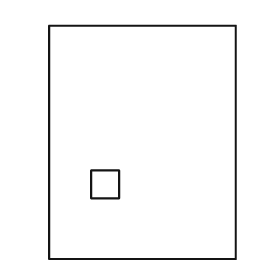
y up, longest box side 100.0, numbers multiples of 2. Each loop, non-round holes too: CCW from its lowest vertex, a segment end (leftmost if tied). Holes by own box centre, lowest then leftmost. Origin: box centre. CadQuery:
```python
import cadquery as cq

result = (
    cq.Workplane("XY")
    .moveTo(-40.0, -50.0)
    .lineTo(40.0, -50.0)
    .lineTo(40.0, 50.0)
    .lineTo(-40.0, 50.0)
    .close()
    .moveTo(-22.0, -24.0)
    .lineTo(-10.0, -24.0)
    .lineTo(-10.0, -12.0)
    .lineTo(-22.0, -12.0)
    .close()
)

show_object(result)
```